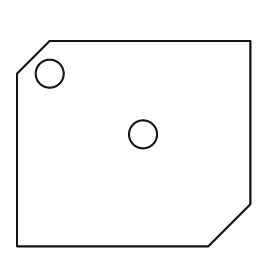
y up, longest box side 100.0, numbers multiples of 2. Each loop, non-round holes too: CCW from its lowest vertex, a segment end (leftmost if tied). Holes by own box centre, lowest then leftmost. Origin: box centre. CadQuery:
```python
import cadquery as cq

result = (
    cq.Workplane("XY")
    .moveTo(-50.0, -44.0)
    .lineTo(32.0, -44.0)
    .lineTo(50.0, -26.0)
    .lineTo(50.0, 44.0)
    .lineTo(-36.0, 44.0)
    .lineTo(-50.0, 30.0)
    .close()
    .moveTo(4.0, 4.0)
    .circle(6.0)
    .moveTo(-36.0, 30.0)
    .circle(6.0)
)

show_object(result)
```